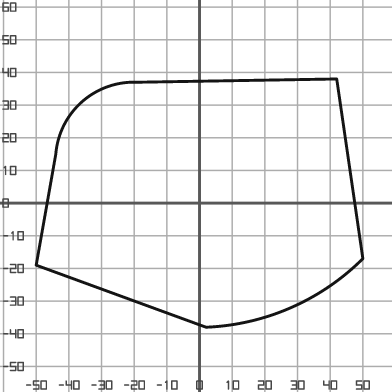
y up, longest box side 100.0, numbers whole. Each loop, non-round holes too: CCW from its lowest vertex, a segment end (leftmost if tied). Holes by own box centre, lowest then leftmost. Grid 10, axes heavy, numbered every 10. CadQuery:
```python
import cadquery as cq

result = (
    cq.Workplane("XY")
    .moveTo(2.0, -38.0)
    .threePointArc((28.0, -32.0), (50.0, -17.0))
    .lineTo(42.0, 38.0)
    .lineTo(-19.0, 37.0)
    .threePointArc((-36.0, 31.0), (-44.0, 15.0))
    .lineTo(-50.0, -19.0)
    .close()
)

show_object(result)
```